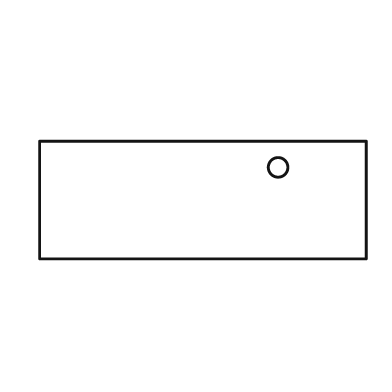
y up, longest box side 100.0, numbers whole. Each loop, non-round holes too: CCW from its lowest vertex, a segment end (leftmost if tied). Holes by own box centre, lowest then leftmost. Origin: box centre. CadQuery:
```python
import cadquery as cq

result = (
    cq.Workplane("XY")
    .moveTo(-50.0, -18.0)
    .lineTo(50.0, -18.0)
    .lineTo(50.0, 18.0)
    .lineTo(-50.0, 18.0)
    .close()
    .moveTo(23.0, 10.0)
    .circle(3.0)
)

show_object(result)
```